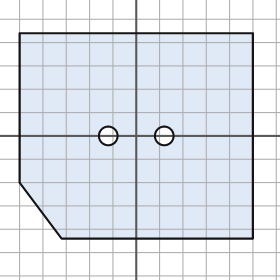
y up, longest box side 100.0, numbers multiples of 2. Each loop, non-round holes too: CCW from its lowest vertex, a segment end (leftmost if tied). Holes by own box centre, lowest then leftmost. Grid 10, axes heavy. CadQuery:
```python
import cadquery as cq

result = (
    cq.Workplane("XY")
    .moveTo(-32.0, -44.0)
    .lineTo(50.0, -44.0)
    .lineTo(50.0, 44.0)
    .lineTo(-50.0, 44.0)
    .lineTo(-50.0, -20.0)
    .close()
    .moveTo(-12.0, 0.0)
    .circle(4.0)
    .moveTo(12.0, 0.0)
    .circle(4.0)
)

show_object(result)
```